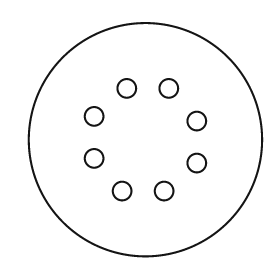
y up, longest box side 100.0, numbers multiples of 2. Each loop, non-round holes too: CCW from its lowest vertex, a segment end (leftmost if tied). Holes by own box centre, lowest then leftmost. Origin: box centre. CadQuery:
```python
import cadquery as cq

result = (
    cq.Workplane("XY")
    .moveTo(0.0, 0.0)
    .circle(50.0)
    .moveTo(-10.0, -22.0)
    .circle(4.0)
    .moveTo(8.0, -22.0)
    .circle(4.0)
    .moveTo(22.0, -10.0)
    .circle(4.0)
    .moveTo(-22.0, -8.0)
    .circle(4.0)
    .moveTo(22.0, 8.0)
    .circle(4.0)
    .moveTo(-22.0, 10.0)
    .circle(4.0)
    .moveTo(-8.0, 22.0)
    .circle(4.0)
    .moveTo(10.0, 22.0)
    .circle(4.0)
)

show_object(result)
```